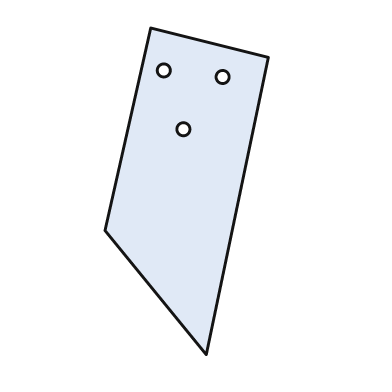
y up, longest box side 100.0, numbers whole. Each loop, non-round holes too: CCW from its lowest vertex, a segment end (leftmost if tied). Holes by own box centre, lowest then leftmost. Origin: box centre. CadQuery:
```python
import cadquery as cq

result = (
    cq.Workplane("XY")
    .moveTo(6.0, -50.0)
    .lineTo(25.0, 41.0)
    .lineTo(-11.0, 50.0)
    .lineTo(-25.0, -12.0)
    .close()
    .moveTo(-1.0, 19.0)
    .circle(2.0)
    .moveTo(11.0, 35.0)
    .circle(2.0)
    .moveTo(-7.0, 37.0)
    .circle(2.0)
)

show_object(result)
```